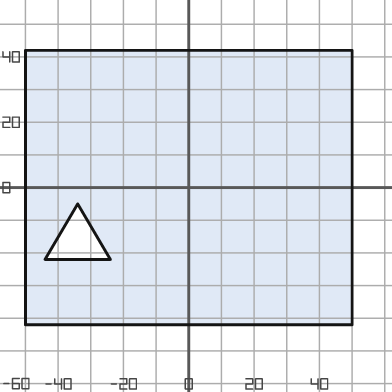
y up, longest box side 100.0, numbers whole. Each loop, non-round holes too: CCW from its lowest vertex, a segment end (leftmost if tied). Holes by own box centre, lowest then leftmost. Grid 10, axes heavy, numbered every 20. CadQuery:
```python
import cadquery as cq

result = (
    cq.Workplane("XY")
    .moveTo(-50.0, -42.0)
    .lineTo(50.0, -42.0)
    .lineTo(50.0, 42.0)
    .lineTo(-50.0, 42.0)
    .close()
    .moveTo(-44.0, -22.0)
    .lineTo(-24.0, -22.0)
    .lineTo(-34.0, -5.0)
    .close()
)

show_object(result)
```